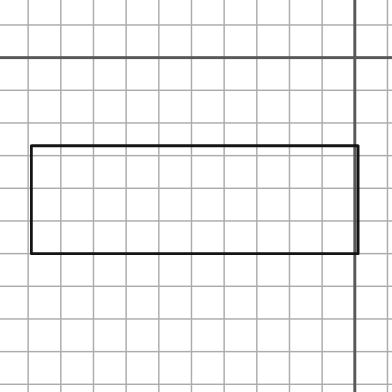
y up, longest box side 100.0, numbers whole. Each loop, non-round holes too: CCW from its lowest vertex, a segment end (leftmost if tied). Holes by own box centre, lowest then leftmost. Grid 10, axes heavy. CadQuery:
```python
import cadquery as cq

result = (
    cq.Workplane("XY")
    .moveTo(-99.0, -60.0)
    .lineTo(1.0, -60.0)
    .lineTo(1.0, -27.0)
    .lineTo(-99.0, -27.0)
    .close()
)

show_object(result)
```